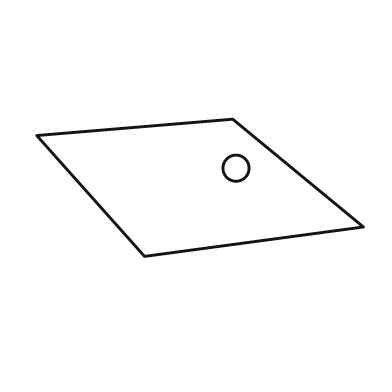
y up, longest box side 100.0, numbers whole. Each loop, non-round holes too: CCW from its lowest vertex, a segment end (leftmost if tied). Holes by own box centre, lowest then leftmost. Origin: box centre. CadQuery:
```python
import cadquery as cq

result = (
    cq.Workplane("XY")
    .moveTo(-17.0, -21.0)
    .lineTo(50.0, -12.0)
    .lineTo(10.0, 21.0)
    .lineTo(-50.0, 16.0)
    .close()
    .moveTo(11.0, 6.0)
    .circle(4.0)
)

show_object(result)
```